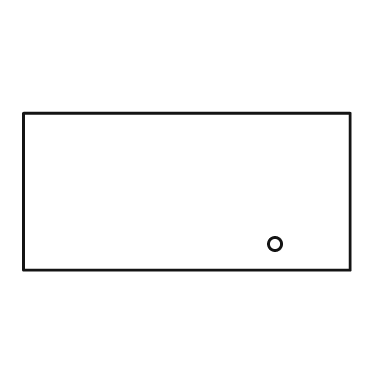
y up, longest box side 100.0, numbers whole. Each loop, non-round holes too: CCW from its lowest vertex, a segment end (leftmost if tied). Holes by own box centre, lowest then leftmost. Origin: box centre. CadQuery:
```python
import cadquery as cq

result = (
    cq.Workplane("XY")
    .moveTo(-50.0, -24.0)
    .lineTo(50.0, -24.0)
    .lineTo(50.0, 24.0)
    .lineTo(-50.0, 24.0)
    .close()
    .moveTo(27.0, -16.0)
    .circle(2.0)
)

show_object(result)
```